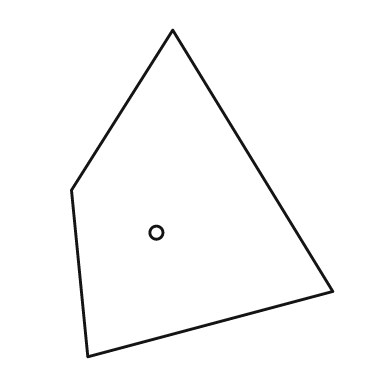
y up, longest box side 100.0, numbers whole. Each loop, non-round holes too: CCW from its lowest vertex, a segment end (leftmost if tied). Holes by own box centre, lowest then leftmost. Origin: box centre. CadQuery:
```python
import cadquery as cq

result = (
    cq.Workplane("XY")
    .moveTo(-35.0, -50.0)
    .lineTo(40.0, -30.0)
    .lineTo(-9.0, 50.0)
    .lineTo(-40.0, 1.0)
    .close()
    .moveTo(-14.0, -12.0)
    .circle(2.0)
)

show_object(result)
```